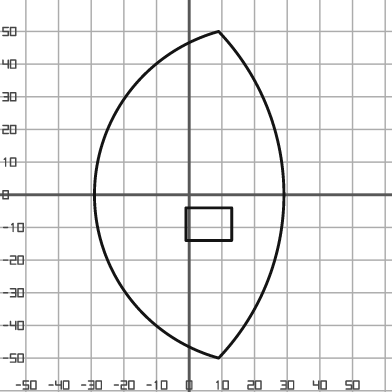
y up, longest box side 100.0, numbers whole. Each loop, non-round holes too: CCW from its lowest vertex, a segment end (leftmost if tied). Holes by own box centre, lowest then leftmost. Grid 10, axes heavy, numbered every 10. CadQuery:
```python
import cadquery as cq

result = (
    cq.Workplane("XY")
    .moveTo(9.0, -50.0)
    .threePointArc((29.0, 0.0), (9.0, 50.0))
    .threePointArc((-29.0, 0.0), (9.0, -50.0))
    .close()
    .moveTo(-1.0, -14.0)
    .lineTo(13.0, -14.0)
    .lineTo(13.0, -4.0)
    .lineTo(-1.0, -4.0)
    .close()
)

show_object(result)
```